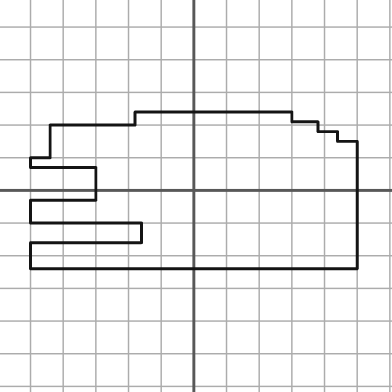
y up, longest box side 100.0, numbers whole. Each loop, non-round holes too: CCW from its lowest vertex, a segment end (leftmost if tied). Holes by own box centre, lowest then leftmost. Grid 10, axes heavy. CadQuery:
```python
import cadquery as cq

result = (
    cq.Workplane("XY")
    .moveTo(-50.0, -24.0)
    .lineTo(50.0, -24.0)
    .lineTo(50.0, 15.0)
    .lineTo(44.0, 15.0)
    .lineTo(44.0, 18.0)
    .lineTo(38.0, 18.0)
    .lineTo(38.0, 21.0)
    .lineTo(30.0, 21.0)
    .lineTo(30.0, 24.0)
    .lineTo(-18.0, 24.0)
    .lineTo(-18.0, 20.0)
    .lineTo(-44.0, 20.0)
    .lineTo(-44.0, 10.0)
    .lineTo(-50.0, 10.0)
    .lineTo(-50.0, 7.0)
    .lineTo(-30.0, 7.0)
    .lineTo(-30.0, -3.0)
    .lineTo(-50.0, -3.0)
    .lineTo(-50.0, -10.0)
    .lineTo(-16.0, -10.0)
    .lineTo(-16.0, -16.0)
    .lineTo(-50.0, -16.0)
    .close()
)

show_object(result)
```